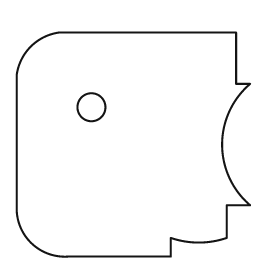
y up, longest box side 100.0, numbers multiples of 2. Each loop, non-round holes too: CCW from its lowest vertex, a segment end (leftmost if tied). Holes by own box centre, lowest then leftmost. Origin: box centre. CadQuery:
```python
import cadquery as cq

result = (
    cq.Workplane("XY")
    .moveTo(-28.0, -48.0)
    .lineTo(16.0, -48.0)
    .lineTo(16.0, -40.0)
    .threePointArc((28.0, -42.0), (40.0, -40.0))
    .lineTo(40.0, -26.0)
    .lineTo(50.0, -26.0)
    .threePointArc((38.0, 0.0), (50.0, 26.0))
    .lineTo(44.0, 26.0)
    .lineTo(44.0, 48.0)
    .lineTo(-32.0, 48.0)
    .threePointArc((-44.0, 42.0), (-50.0, 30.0))
    .lineTo(-50.0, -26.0)
    .threePointArc((-44.0, -42.0), (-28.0, -48.0))
    .close()
    .moveTo(-18.0, 16.0)
    .circle(6.0)
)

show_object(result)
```